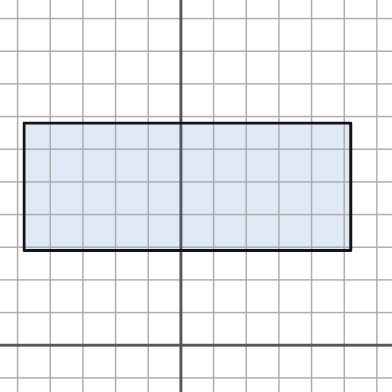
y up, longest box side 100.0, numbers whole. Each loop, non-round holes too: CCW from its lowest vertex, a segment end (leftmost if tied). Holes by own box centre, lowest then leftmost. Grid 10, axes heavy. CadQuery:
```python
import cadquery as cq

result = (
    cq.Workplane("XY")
    .moveTo(-48.0, 29.0)
    .lineTo(52.0, 29.0)
    .lineTo(52.0, 68.0)
    .lineTo(-48.0, 68.0)
    .close()
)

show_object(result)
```